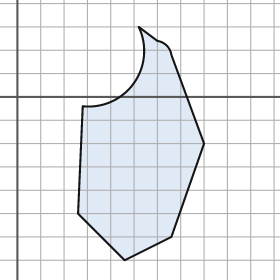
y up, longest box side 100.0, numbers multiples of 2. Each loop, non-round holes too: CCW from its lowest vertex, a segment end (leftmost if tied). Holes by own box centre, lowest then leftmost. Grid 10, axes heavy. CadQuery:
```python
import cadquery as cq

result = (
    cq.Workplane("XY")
    .moveTo(46.0, -70.0)
    .lineTo(66.0, -60.0)
    .lineTo(80.0, -20.0)
    .lineTo(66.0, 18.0)
    .threePointArc((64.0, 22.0), (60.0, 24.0))
    .lineTo(52.0, 30.0)
    .threePointArc((50.0, 6.0), (28.0, -4.0))
    .lineTo(26.0, -50.0)
    .close()
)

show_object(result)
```